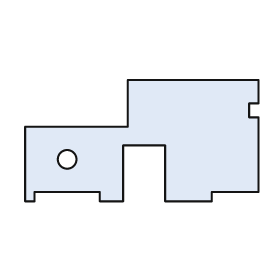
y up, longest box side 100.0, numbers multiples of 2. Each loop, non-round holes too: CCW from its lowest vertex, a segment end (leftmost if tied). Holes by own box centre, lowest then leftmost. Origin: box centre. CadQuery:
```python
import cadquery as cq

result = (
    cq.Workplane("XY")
    .moveTo(-50.0, -26.0)
    .lineTo(-46.0, -26.0)
    .lineTo(-46.0, -22.0)
    .lineTo(-18.0, -22.0)
    .lineTo(-18.0, -26.0)
    .lineTo(-8.0, -26.0)
    .lineTo(-8.0, -2.0)
    .lineTo(10.0, -2.0)
    .lineTo(10.0, -26.0)
    .lineTo(30.0, -26.0)
    .lineTo(30.0, -22.0)
    .lineTo(50.0, -22.0)
    .lineTo(50.0, 10.0)
    .lineTo(46.0, 10.0)
    .lineTo(46.0, 16.0)
    .lineTo(50.0, 16.0)
    .lineTo(50.0, 26.0)
    .lineTo(-6.0, 26.0)
    .lineTo(-6.0, 6.0)
    .lineTo(-50.0, 6.0)
    .close()
    .moveTo(-32.0, -8.0)
    .circle(4.0)
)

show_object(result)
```